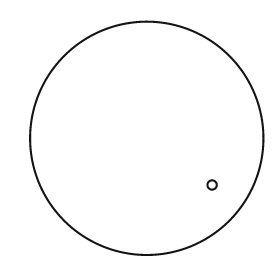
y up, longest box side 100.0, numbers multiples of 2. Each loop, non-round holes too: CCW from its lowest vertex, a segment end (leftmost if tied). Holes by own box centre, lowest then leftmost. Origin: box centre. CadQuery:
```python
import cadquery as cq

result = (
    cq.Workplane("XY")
    .moveTo(0.0, 0.0)
    .circle(50.0)
    .moveTo(28.0, -20.0)
    .circle(2.0)
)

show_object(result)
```